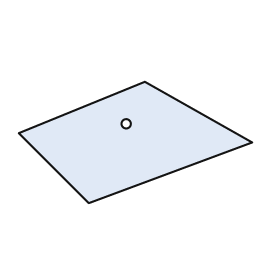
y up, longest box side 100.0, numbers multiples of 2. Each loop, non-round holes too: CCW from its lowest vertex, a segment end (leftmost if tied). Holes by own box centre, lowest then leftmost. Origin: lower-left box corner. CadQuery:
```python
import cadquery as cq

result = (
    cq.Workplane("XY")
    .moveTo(30.0, 0.0)
    .lineTo(100.0, 26.0)
    .lineTo(54.0, 52.0)
    .lineTo(0.0, 30.0)
    .close()
    .moveTo(46.0, 34.0)
    .circle(2.0)
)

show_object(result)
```